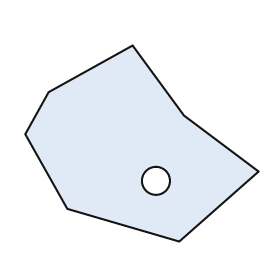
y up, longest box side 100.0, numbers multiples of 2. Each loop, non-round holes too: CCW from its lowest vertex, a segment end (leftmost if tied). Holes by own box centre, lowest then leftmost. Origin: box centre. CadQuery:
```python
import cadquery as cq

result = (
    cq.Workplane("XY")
    .moveTo(16.0, -42.0)
    .lineTo(50.0, -12.0)
    .lineTo(18.0, 12.0)
    .lineTo(-4.0, 42.0)
    .lineTo(-40.0, 22.0)
    .lineTo(-50.0, 4.0)
    .lineTo(-32.0, -28.0)
    .close()
    .moveTo(6.0, -16.0)
    .circle(6.0)
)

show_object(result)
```